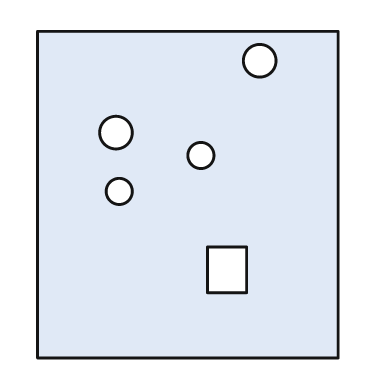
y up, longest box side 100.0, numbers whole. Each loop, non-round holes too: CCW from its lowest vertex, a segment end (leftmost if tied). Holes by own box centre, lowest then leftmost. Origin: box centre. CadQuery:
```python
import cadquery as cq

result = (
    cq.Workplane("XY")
    .moveTo(-46.0, -50.0)
    .lineTo(46.0, -50.0)
    .lineTo(46.0, 50.0)
    .lineTo(-46.0, 50.0)
    .close()
    .moveTo(6.0, -30.0)
    .lineTo(18.0, -30.0)
    .lineTo(18.0, -16.0)
    .lineTo(6.0, -16.0)
    .close()
    .moveTo(-21.0, 1.0)
    .circle(4.0)
    .moveTo(4.0, 12.0)
    .circle(4.0)
    .moveTo(-22.0, 19.0)
    .circle(5.0)
    .moveTo(22.0, 41.0)
    .circle(5.0)
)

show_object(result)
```